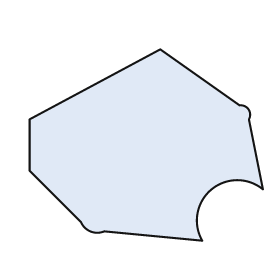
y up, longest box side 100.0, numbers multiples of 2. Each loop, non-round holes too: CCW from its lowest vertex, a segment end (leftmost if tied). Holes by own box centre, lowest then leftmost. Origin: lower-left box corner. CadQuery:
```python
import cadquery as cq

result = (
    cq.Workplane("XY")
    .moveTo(74.0, 0.0)
    .threePointArc((78.0, 22.0), (100.0, 22.0))
    .lineTo(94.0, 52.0)
    .threePointArc((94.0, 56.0), (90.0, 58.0))
    .lineTo(56.0, 82.0)
    .lineTo(0.0, 52.0)
    .lineTo(0.0, 30.0)
    .lineTo(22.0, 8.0)
    .threePointArc((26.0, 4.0), (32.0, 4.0))
    .close()
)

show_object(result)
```